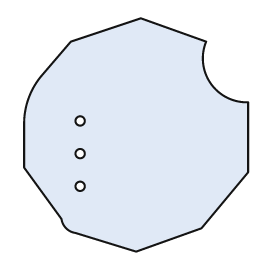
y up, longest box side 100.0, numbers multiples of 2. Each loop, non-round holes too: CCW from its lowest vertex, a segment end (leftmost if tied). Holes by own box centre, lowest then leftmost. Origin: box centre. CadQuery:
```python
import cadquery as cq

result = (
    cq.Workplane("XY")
    .moveTo(0.0, -50.0)
    .lineTo(28.0, -40.0)
    .lineTo(48.0, -16.0)
    .lineTo(48.0, 14.0)
    .threePointArc((32.0, 22.0), (30.0, 40.0))
    .lineTo(2.0, 50.0)
    .lineTo(-28.0, 40.0)
    .lineTo(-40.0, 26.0)
    .threePointArc((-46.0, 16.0), (-48.0, 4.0))
    .lineTo(-48.0, -14.0)
    .lineTo(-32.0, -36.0)
    .threePointArc((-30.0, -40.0), (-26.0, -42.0))
    .close()
    .moveTo(-24.0, -22.0)
    .circle(2.0)
    .moveTo(-24.0, -8.0)
    .circle(2.0)
    .moveTo(-24.0, 6.0)
    .circle(2.0)
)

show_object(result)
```